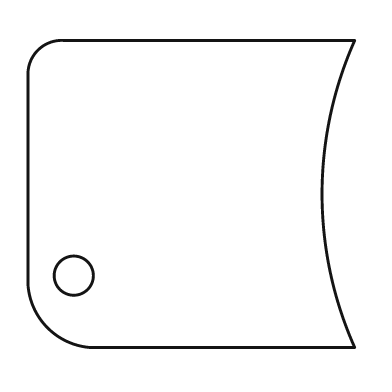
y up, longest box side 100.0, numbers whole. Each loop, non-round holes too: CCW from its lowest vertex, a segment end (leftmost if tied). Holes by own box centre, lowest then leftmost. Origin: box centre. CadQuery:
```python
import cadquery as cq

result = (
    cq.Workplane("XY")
    .moveTo(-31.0, -47.0)
    .lineTo(50.0, -47.0)
    .threePointArc((40.0, 0.0), (50.0, 47.0))
    .lineTo(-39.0, 47.0)
    .threePointArc((-47.0, 44.0), (-50.0, 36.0))
    .lineTo(-50.0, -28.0)
    .threePointArc((-44.0, -41.0), (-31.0, -47.0))
    .close()
    .moveTo(-36.0, -25.0)
    .circle(6.0)
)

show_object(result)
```